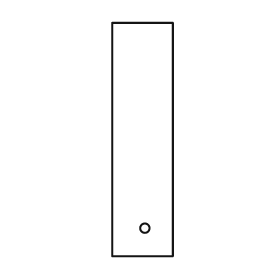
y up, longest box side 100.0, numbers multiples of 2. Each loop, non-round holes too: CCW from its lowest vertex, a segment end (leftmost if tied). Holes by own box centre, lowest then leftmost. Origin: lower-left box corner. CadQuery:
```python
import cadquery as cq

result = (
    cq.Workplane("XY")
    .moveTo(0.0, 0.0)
    .lineTo(26.0, 0.0)
    .lineTo(26.0, 100.0)
    .lineTo(0.0, 100.0)
    .close()
    .moveTo(14.0, 12.0)
    .circle(2.0)
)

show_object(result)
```